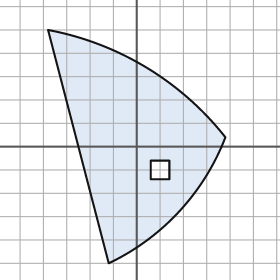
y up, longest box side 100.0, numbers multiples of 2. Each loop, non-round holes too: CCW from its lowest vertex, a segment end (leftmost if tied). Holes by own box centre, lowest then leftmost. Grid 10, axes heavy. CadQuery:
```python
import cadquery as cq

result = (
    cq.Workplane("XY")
    .moveTo(-12.0, -50.0)
    .threePointArc((18.0, -28.0), (38.0, 4.0))
    .threePointArc((4.0, 34.0), (-38.0, 50.0))
    .close()
    .moveTo(6.0, -14.0)
    .lineTo(14.0, -14.0)
    .lineTo(14.0, -6.0)
    .lineTo(6.0, -6.0)
    .close()
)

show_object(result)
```